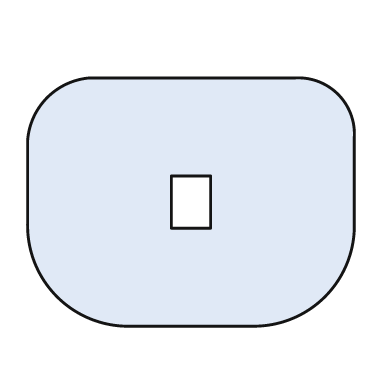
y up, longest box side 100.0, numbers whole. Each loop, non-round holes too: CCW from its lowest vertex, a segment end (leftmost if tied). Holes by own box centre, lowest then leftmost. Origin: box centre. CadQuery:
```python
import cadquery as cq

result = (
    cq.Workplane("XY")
    .moveTo(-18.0, -38.0)
    .lineTo(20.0, -38.0)
    .threePointArc((41.0, -29.0), (50.0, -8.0))
    .lineTo(50.0, 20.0)
    .threePointArc((45.0, 33.0), (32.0, 38.0))
    .lineTo(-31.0, 38.0)
    .threePointArc((-44.0, 32.0), (-50.0, 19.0))
    .lineTo(-50.0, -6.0)
    .threePointArc((-41.0, -29.0), (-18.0, -38.0))
    .close()
    .moveTo(-6.0, -8.0)
    .lineTo(6.0, -8.0)
    .lineTo(6.0, 8.0)
    .lineTo(-6.0, 8.0)
    .close()
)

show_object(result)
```